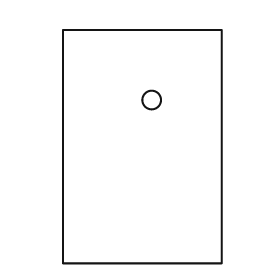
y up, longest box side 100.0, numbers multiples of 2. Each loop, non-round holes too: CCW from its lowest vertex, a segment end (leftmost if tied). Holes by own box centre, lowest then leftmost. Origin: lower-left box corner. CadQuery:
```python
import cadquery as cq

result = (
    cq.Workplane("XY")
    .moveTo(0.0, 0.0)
    .lineTo(68.0, 0.0)
    .lineTo(68.0, 100.0)
    .lineTo(0.0, 100.0)
    .close()
    .moveTo(38.0, 70.0)
    .circle(4.0)
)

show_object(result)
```